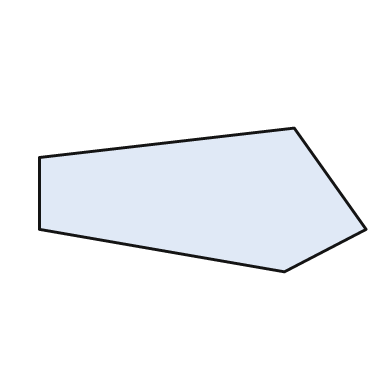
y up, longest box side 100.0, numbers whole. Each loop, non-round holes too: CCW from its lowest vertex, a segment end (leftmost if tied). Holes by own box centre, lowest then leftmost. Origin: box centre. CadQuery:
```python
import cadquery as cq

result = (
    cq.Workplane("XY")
    .moveTo(25.0, -22.0)
    .lineTo(50.0, -9.0)
    .lineTo(28.0, 22.0)
    .lineTo(-50.0, 13.0)
    .lineTo(-50.0, -9.0)
    .close()
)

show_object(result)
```